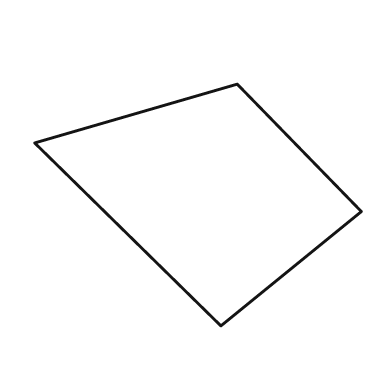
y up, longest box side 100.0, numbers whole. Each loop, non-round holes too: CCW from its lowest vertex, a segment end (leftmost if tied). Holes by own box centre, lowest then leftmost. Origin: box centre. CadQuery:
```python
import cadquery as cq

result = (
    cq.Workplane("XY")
    .moveTo(7.0, -37.0)
    .lineTo(50.0, -2.0)
    .lineTo(12.0, 37.0)
    .lineTo(-50.0, 19.0)
    .close()
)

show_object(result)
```